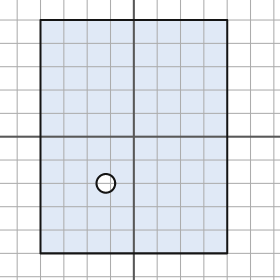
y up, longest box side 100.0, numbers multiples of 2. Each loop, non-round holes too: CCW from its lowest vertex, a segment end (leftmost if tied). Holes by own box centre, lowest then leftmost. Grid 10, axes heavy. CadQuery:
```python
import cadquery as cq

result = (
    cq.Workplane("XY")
    .moveTo(-40.0, -50.0)
    .lineTo(40.0, -50.0)
    .lineTo(40.0, 50.0)
    .lineTo(-40.0, 50.0)
    .close()
    .moveTo(-12.0, -20.0)
    .circle(4.0)
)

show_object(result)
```